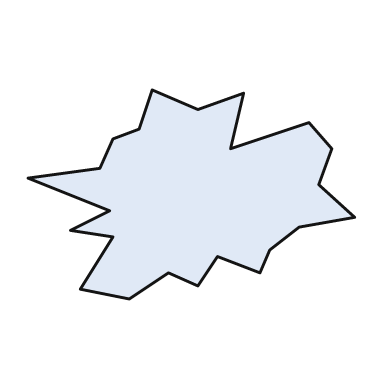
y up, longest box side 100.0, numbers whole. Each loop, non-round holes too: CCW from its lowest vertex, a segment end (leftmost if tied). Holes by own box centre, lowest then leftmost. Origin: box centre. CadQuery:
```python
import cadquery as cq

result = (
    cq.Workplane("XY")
    .moveTo(-19.0, -32.0)
    .lineTo(-7.0, -24.0)
    .lineTo(2.0, -28.0)
    .lineTo(8.0, -19.0)
    .lineTo(21.0, -24.0)
    .lineTo(24.0, -17.0)
    .lineTo(33.0, -10.0)
    .lineTo(50.0, -7.0)
    .lineTo(39.0, 3.0)
    .lineTo(43.0, 14.0)
    .lineTo(36.0, 22.0)
    .lineTo(12.0, 14.0)
    .lineTo(16.0, 31.0)
    .lineTo(2.0, 26.0)
    .lineTo(-12.0, 32.0)
    .lineTo(-16.0, 20.0)
    .lineTo(-24.0, 17.0)
    .lineTo(-28.0, 8.0)
    .lineTo(-50.0, 5.0)
    .lineTo(-25.0, -5.0)
    .lineTo(-37.0, -11.0)
    .lineTo(-24.0, -13.0)
    .lineTo(-34.0, -29.0)
    .close()
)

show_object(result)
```